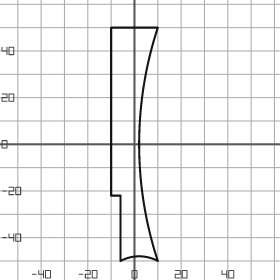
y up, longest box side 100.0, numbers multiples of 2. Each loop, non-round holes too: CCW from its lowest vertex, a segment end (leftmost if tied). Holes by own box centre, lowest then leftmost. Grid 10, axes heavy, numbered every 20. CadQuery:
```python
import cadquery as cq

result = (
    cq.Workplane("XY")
    .moveTo(-6.0, -50.0)
    .threePointArc((2.0, -48.0), (10.0, -50.0))
    .threePointArc((2.0, 0.0), (10.0, 50.0))
    .lineTo(-10.0, 50.0)
    .lineTo(-10.0, -22.0)
    .lineTo(-6.0, -22.0)
    .close()
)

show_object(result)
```